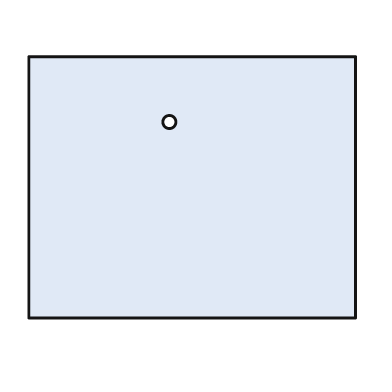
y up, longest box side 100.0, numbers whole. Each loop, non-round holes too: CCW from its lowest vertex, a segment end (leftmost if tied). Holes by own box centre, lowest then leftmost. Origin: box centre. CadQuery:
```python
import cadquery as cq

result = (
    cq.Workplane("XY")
    .moveTo(-50.0, -40.0)
    .lineTo(50.0, -40.0)
    .lineTo(50.0, 40.0)
    .lineTo(-50.0, 40.0)
    .close()
    .moveTo(-7.0, 20.0)
    .circle(2.0)
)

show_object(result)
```